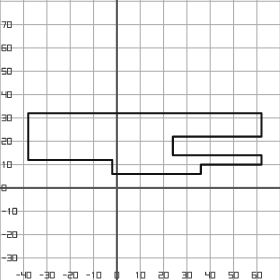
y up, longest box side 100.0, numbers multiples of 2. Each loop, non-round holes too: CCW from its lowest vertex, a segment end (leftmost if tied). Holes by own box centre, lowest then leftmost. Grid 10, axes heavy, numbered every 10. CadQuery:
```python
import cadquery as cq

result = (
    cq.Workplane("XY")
    .moveTo(-2.0, 6.0)
    .lineTo(36.0, 6.0)
    .lineTo(36.0, 10.0)
    .lineTo(62.0, 10.0)
    .lineTo(62.0, 14.0)
    .lineTo(24.0, 14.0)
    .lineTo(24.0, 22.0)
    .lineTo(62.0, 22.0)
    .lineTo(62.0, 32.0)
    .lineTo(-38.0, 32.0)
    .lineTo(-38.0, 12.0)
    .lineTo(-2.0, 12.0)
    .close()
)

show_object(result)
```